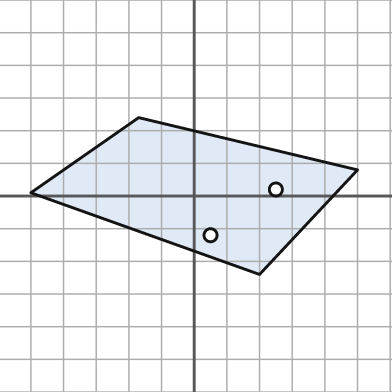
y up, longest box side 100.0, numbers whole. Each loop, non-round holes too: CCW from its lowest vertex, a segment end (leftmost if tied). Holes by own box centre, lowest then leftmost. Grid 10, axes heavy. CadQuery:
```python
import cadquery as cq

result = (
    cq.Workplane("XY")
    .moveTo(20.0, -24.0)
    .lineTo(50.0, 8.0)
    .lineTo(-17.0, 24.0)
    .lineTo(-50.0, 1.0)
    .close()
    .moveTo(5.0, -12.0)
    .circle(2.0)
    .moveTo(25.0, 2.0)
    .circle(2.0)
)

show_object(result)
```